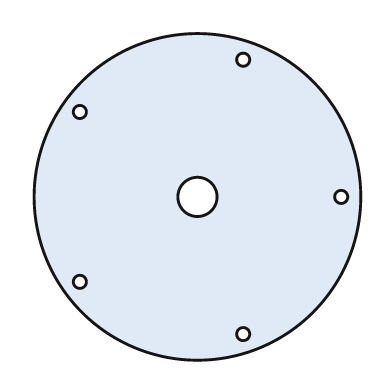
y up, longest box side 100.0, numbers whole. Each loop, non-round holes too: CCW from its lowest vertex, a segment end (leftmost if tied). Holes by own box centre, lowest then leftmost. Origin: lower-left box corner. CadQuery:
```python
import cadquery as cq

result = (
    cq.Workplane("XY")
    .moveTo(50.0, 50.0)
    .circle(50.0)
    .moveTo(64.0, 8.0)
    .circle(2.0)
    .moveTo(14.0, 24.0)
    .circle(2.0)
    .moveTo(50.0, 50.0)
    .circle(6.0)
    .moveTo(94.0, 50.0)
    .circle(2.0)
    .moveTo(14.0, 76.0)
    .circle(2.0)
    .moveTo(64.0, 92.0)
    .circle(2.0)
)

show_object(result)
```